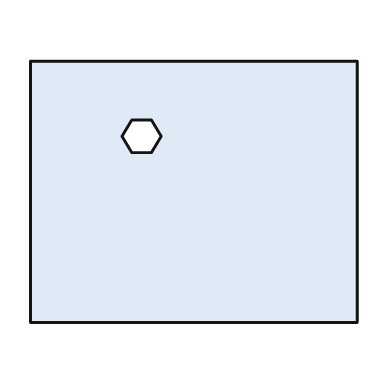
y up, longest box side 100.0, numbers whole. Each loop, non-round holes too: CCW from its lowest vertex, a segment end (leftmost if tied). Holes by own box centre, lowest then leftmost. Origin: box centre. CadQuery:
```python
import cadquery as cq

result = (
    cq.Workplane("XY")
    .moveTo(-50.0, -40.0)
    .lineTo(50.0, -40.0)
    .lineTo(50.0, 40.0)
    .lineTo(-50.0, 40.0)
    .close()
    .moveTo(-19.0, 12.0)
    .lineTo(-13.0, 12.0)
    .lineTo(-10.0, 17.0)
    .lineTo(-13.0, 22.0)
    .lineTo(-19.0, 22.0)
    .lineTo(-22.0, 17.0)
    .close()
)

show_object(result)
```